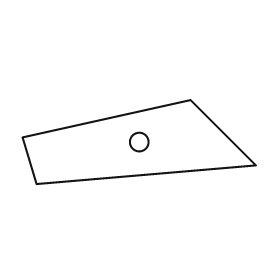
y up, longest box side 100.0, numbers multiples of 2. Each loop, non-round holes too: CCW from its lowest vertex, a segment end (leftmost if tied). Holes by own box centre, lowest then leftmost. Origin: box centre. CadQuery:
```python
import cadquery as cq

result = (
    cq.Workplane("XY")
    .moveTo(-44.0, -18.0)
    .lineTo(50.0, -10.0)
    .lineTo(22.0, 18.0)
    .lineTo(-50.0, 2.0)
    .close()
    .moveTo(0.0, 0.0)
    .circle(4.0)
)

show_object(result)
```